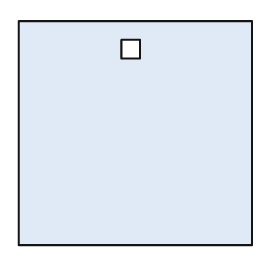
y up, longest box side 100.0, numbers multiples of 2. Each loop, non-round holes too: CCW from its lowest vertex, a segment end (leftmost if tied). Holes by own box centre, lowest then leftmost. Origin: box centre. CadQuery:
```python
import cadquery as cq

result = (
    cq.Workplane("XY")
    .moveTo(-50.0, -48.0)
    .lineTo(50.0, -48.0)
    .lineTo(50.0, 48.0)
    .lineTo(-50.0, 48.0)
    .close()
    .moveTo(-6.0, 32.0)
    .lineTo(2.0, 32.0)
    .lineTo(2.0, 40.0)
    .lineTo(-6.0, 40.0)
    .close()
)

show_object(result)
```